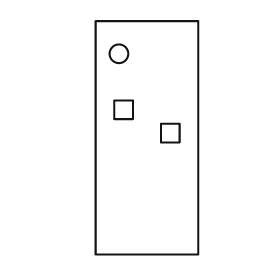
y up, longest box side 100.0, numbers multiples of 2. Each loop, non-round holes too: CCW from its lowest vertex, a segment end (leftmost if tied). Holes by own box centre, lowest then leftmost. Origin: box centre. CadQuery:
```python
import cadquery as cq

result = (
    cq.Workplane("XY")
    .moveTo(-22.0, -50.0)
    .lineTo(22.0, -50.0)
    .lineTo(22.0, 50.0)
    .lineTo(-22.0, 50.0)
    .close()
    .moveTo(6.0, -2.0)
    .lineTo(14.0, -2.0)
    .lineTo(14.0, 6.0)
    .lineTo(6.0, 6.0)
    .close()
    .moveTo(-14.0, 8.0)
    .lineTo(-6.0, 8.0)
    .lineTo(-6.0, 16.0)
    .lineTo(-14.0, 16.0)
    .close()
    .moveTo(-12.0, 36.0)
    .circle(4.0)
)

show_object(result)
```